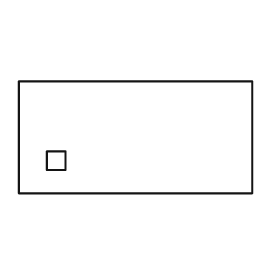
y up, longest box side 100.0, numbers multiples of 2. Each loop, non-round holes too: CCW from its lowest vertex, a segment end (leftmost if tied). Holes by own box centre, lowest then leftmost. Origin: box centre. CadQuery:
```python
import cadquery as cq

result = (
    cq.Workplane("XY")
    .moveTo(-50.0, -24.0)
    .lineTo(50.0, -24.0)
    .lineTo(50.0, 24.0)
    .lineTo(-50.0, 24.0)
    .close()
    .moveTo(-38.0, -14.0)
    .lineTo(-30.0, -14.0)
    .lineTo(-30.0, -6.0)
    .lineTo(-38.0, -6.0)
    .close()
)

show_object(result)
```